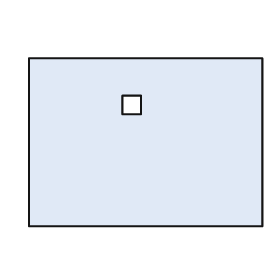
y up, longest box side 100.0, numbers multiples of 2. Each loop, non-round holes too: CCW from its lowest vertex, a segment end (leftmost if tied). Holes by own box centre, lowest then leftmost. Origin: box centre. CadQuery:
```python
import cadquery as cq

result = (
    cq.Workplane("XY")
    .moveTo(-50.0, -36.0)
    .lineTo(50.0, -36.0)
    .lineTo(50.0, 36.0)
    .lineTo(-50.0, 36.0)
    .close()
    .moveTo(-10.0, 12.0)
    .lineTo(-2.0, 12.0)
    .lineTo(-2.0, 20.0)
    .lineTo(-10.0, 20.0)
    .close()
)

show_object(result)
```